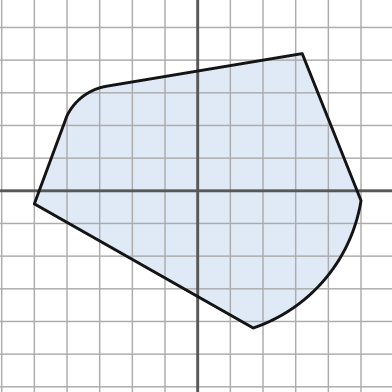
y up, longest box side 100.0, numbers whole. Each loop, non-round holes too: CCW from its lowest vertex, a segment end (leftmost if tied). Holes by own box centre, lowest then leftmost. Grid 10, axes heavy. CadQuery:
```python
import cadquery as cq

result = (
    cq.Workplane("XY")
    .moveTo(17.0, -42.0)
    .threePointArc((39.0, -27.0), (50.0, -3.0))
    .lineTo(32.0, 42.0)
    .lineTo(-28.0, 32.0)
    .threePointArc((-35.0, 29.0), (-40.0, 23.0))
    .lineTo(-50.0, -4.0)
    .close()
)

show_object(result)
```